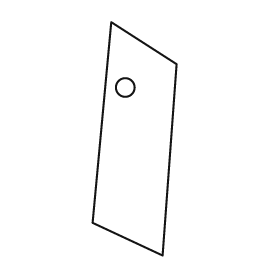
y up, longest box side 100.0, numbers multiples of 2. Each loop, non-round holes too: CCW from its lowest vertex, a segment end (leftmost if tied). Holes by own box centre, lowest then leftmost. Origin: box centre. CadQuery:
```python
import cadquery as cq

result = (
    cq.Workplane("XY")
    .moveTo(12.0, -50.0)
    .lineTo(18.0, 32.0)
    .lineTo(-10.0, 50.0)
    .lineTo(-18.0, -36.0)
    .close()
    .moveTo(-4.0, 22.0)
    .circle(4.0)
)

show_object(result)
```